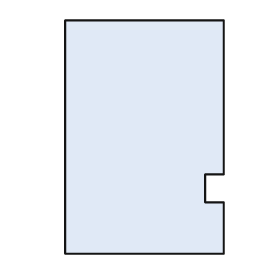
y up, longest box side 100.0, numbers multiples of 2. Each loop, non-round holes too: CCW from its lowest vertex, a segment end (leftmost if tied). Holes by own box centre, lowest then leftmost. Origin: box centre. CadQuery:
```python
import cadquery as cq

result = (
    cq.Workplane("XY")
    .moveTo(-34.0, -50.0)
    .lineTo(34.0, -50.0)
    .lineTo(34.0, -28.0)
    .lineTo(26.0, -28.0)
    .lineTo(26.0, -16.0)
    .lineTo(34.0, -16.0)
    .lineTo(34.0, 50.0)
    .lineTo(-34.0, 50.0)
    .close()
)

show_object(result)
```